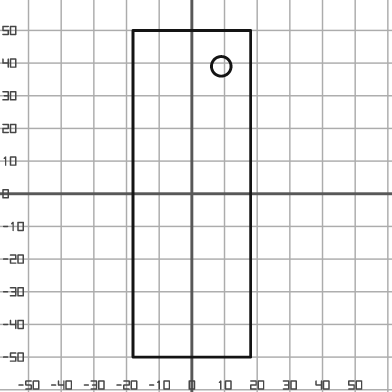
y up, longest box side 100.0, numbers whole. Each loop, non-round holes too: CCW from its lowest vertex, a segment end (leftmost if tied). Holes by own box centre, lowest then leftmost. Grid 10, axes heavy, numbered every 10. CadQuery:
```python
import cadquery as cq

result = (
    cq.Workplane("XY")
    .moveTo(-18.0, -50.0)
    .lineTo(18.0, -50.0)
    .lineTo(18.0, 50.0)
    .lineTo(-18.0, 50.0)
    .close()
    .moveTo(9.0, 39.0)
    .circle(3.0)
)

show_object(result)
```